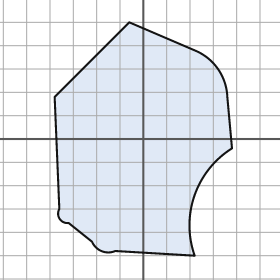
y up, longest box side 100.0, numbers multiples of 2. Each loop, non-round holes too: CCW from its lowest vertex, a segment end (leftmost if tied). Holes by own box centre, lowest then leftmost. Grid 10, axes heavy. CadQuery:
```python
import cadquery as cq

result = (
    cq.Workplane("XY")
    .moveTo(22.0, -50.0)
    .threePointArc((22.0, -24.0), (38.0, -4.0))
    .lineTo(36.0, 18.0)
    .threePointArc((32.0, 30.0), (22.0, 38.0))
    .lineTo(-6.0, 50.0)
    .lineTo(-38.0, 18.0)
    .lineTo(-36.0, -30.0)
    .threePointArc((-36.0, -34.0), (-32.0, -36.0))
    .lineTo(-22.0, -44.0)
    .threePointArc((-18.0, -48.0), (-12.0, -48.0))
    .close()
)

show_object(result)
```